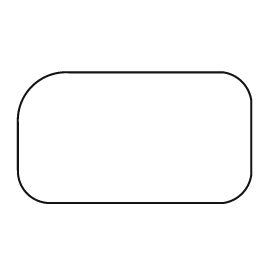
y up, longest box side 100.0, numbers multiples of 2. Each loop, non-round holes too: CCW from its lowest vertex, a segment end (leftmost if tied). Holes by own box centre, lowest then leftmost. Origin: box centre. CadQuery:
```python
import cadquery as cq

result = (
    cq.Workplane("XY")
    .moveTo(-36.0, -28.0)
    .lineTo(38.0, -28.0)
    .threePointArc((46.0, -24.0), (50.0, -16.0))
    .lineTo(50.0, 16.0)
    .threePointArc((46.0, 24.0), (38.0, 28.0))
    .lineTo(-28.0, 28.0)
    .threePointArc((-44.0, 22.0), (-50.0, 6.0))
    .lineTo(-50.0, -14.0)
    .threePointArc((-46.0, -24.0), (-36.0, -28.0))
    .close()
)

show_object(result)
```